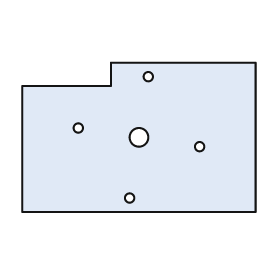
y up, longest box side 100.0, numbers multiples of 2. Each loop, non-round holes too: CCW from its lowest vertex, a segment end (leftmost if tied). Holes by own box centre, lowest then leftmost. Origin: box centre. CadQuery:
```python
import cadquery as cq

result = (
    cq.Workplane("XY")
    .moveTo(-50.0, -32.0)
    .lineTo(50.0, -32.0)
    .lineTo(50.0, 32.0)
    .lineTo(-12.0, 32.0)
    .lineTo(-12.0, 22.0)
    .lineTo(-50.0, 22.0)
    .close()
    .moveTo(-4.0, -26.0)
    .circle(2.0)
    .moveTo(26.0, -4.0)
    .circle(2.0)
    .moveTo(0.0, 0.0)
    .circle(4.0)
    .moveTo(-26.0, 4.0)
    .circle(2.0)
    .moveTo(4.0, 26.0)
    .circle(2.0)
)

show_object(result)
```